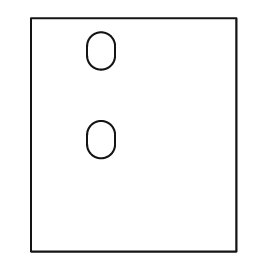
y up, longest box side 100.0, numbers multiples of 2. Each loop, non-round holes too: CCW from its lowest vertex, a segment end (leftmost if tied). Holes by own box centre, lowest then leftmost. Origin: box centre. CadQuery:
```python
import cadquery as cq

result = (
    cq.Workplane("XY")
    .moveTo(-44.0, -50.0)
    .lineTo(44.0, -50.0)
    .lineTo(44.0, 50.0)
    .lineTo(-44.0, 50.0)
    .close()
    .moveTo(-20.0, -4.0)
    .threePointArc((-14.0, -10.0), (-8.0, -4.0))
    .lineTo(-8.0, 0.0)
    .threePointArc((-14.0, 6.0), (-20.0, 0.0))
    .close()
    .moveTo(-20.0, 34.0)
    .threePointArc((-14.0, 28.0), (-8.0, 34.0))
    .lineTo(-8.0, 38.0)
    .threePointArc((-14.0, 44.0), (-20.0, 38.0))
    .close()
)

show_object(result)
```